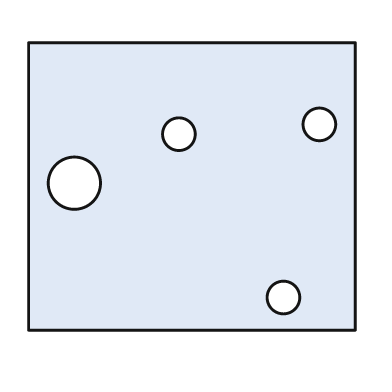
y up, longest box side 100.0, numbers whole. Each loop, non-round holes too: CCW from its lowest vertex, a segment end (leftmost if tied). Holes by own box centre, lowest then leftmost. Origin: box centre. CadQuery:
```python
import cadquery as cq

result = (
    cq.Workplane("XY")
    .moveTo(-50.0, -44.0)
    .lineTo(50.0, -44.0)
    .lineTo(50.0, 44.0)
    .lineTo(-50.0, 44.0)
    .close()
    .moveTo(28.0, -34.0)
    .circle(5.0)
    .moveTo(-36.0, 1.0)
    .circle(8.0)
    .moveTo(-4.0, 16.0)
    .circle(5.0)
    .moveTo(39.0, 19.0)
    .circle(5.0)
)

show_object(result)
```